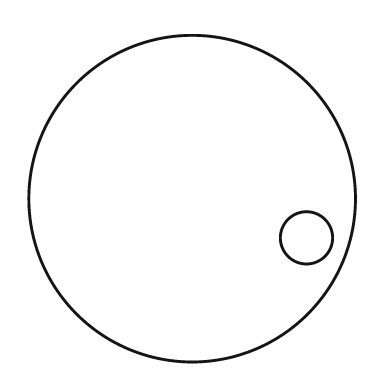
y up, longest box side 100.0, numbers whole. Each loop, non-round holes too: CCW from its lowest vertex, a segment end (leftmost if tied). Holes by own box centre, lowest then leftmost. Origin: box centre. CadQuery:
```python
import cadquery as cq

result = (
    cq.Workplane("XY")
    .moveTo(0.0, 0.0)
    .circle(50.0)
    .moveTo(35.0, -12.0)
    .circle(8.0)
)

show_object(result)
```